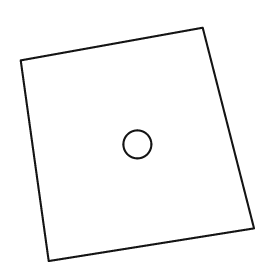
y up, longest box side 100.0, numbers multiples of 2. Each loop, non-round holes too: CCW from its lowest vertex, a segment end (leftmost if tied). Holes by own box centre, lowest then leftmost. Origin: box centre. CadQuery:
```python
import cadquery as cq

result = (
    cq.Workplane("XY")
    .moveTo(-38.0, -50.0)
    .lineTo(50.0, -36.0)
    .lineTo(28.0, 50.0)
    .lineTo(-50.0, 36.0)
    .close()
    .moveTo(0.0, 0.0)
    .circle(6.0)
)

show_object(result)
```